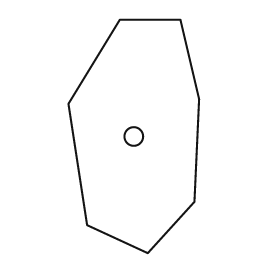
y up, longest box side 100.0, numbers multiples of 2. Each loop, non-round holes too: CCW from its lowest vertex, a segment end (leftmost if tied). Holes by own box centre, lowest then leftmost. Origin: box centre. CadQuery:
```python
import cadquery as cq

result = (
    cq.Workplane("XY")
    .moveTo(6.0, -50.0)
    .lineTo(26.0, -28.0)
    .lineTo(28.0, 16.0)
    .lineTo(20.0, 50.0)
    .lineTo(-6.0, 50.0)
    .lineTo(-28.0, 14.0)
    .lineTo(-20.0, -38.0)
    .close()
    .moveTo(0.0, 0.0)
    .circle(4.0)
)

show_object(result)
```